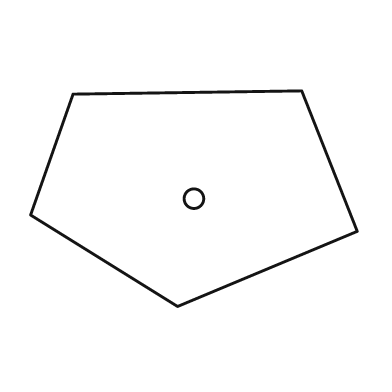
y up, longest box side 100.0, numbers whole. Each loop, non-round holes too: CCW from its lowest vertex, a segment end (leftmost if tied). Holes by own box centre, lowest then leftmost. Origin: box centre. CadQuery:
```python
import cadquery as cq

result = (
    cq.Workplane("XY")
    .moveTo(-5.0, -33.0)
    .lineTo(50.0, -10.0)
    .lineTo(33.0, 33.0)
    .lineTo(-37.0, 32.0)
    .lineTo(-50.0, -5.0)
    .close()
    .moveTo(0.0, 0.0)
    .circle(3.0)
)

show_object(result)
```